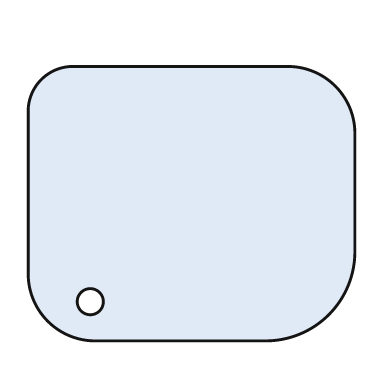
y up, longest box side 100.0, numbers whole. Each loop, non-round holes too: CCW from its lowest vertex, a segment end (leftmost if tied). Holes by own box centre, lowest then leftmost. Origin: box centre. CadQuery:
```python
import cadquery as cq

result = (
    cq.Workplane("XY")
    .moveTo(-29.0, -42.0)
    .lineTo(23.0, -42.0)
    .threePointArc((42.0, -34.0), (50.0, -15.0))
    .lineTo(50.0, 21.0)
    .threePointArc((44.0, 36.0), (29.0, 42.0))
    .lineTo(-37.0, 42.0)
    .threePointArc((-46.0, 38.0), (-50.0, 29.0))
    .lineTo(-50.0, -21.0)
    .threePointArc((-44.0, -36.0), (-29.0, -42.0))
    .close()
    .moveTo(-31.0, -30.0)
    .circle(4.0)
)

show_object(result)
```